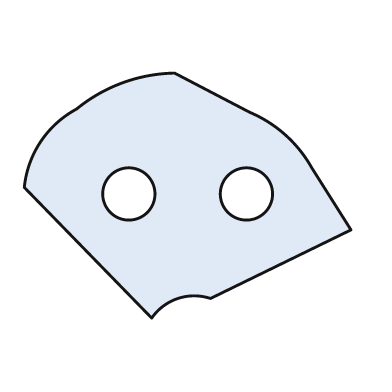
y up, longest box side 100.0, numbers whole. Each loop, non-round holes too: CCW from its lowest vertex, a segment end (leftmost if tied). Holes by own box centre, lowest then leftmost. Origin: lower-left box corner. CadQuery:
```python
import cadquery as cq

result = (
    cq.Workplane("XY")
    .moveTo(39.0, 0.0)
    .threePointArc((47.0, 6.0), (57.0, 6.0))
    .lineTo(100.0, 27.0)
    .lineTo(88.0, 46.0)
    .threePointArc((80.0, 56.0), (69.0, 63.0))
    .lineTo(46.0, 75.0)
    .threePointArc((30.0, 72.0), (16.0, 64.0))
    .threePointArc((5.0, 54.0), (0.0, 40.0))
    .close()
    .moveTo(32.0, 38.0)
    .circle(8.0)
    .moveTo(68.0, 38.0)
    .circle(8.0)
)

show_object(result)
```